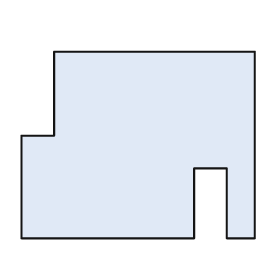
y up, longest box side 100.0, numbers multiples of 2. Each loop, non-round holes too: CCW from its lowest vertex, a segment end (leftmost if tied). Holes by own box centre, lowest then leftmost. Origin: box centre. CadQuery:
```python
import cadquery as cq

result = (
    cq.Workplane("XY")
    .moveTo(-50.0, -40.0)
    .lineTo(24.0, -40.0)
    .lineTo(24.0, -10.0)
    .lineTo(38.0, -10.0)
    .lineTo(38.0, -40.0)
    .lineTo(50.0, -40.0)
    .lineTo(50.0, 40.0)
    .lineTo(-36.0, 40.0)
    .lineTo(-36.0, 4.0)
    .lineTo(-50.0, 4.0)
    .close()
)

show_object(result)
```